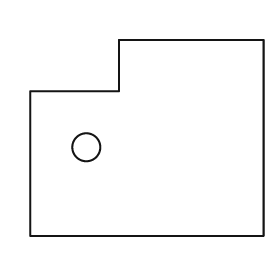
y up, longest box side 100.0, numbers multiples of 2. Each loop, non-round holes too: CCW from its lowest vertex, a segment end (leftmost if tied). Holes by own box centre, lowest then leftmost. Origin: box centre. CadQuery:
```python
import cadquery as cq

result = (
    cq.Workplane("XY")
    .moveTo(-50.0, -42.0)
    .lineTo(50.0, -42.0)
    .lineTo(50.0, 42.0)
    .lineTo(-12.0, 42.0)
    .lineTo(-12.0, 20.0)
    .lineTo(-50.0, 20.0)
    .close()
    .moveTo(-26.0, -4.0)
    .circle(6.0)
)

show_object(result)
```